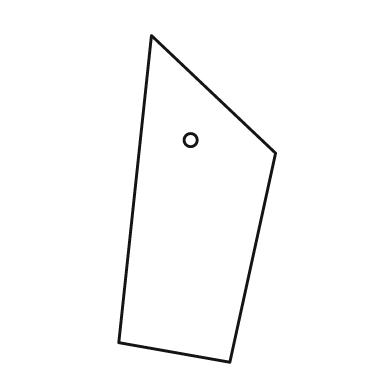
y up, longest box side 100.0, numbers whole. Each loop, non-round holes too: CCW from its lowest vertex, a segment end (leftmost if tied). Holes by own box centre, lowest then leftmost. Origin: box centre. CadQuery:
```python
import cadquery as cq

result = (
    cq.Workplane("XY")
    .moveTo(10.0, -50.0)
    .lineTo(24.0, 14.0)
    .lineTo(-14.0, 50.0)
    .lineTo(-24.0, -44.0)
    .close()
    .moveTo(-2.0, 18.0)
    .circle(2.0)
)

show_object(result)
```